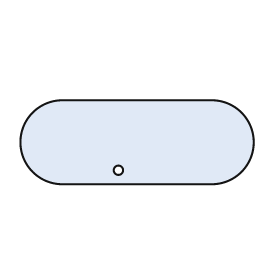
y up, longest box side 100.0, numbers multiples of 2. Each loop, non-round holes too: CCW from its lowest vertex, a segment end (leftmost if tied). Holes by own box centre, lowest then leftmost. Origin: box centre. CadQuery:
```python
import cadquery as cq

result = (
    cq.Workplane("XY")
    .moveTo(-32.0, -18.0)
    .lineTo(32.0, -18.0)
    .threePointArc((50.0, 0.0), (32.0, 18.0))
    .lineTo(-32.0, 18.0)
    .threePointArc((-50.0, 0.0), (-32.0, -18.0))
    .close()
    .moveTo(-8.0, -12.0)
    .circle(2.0)
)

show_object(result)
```